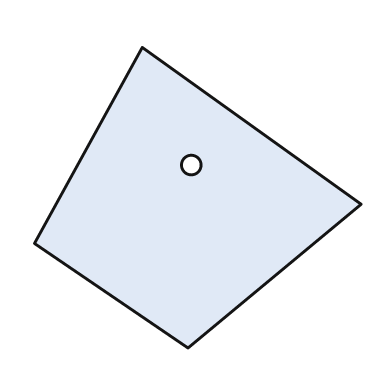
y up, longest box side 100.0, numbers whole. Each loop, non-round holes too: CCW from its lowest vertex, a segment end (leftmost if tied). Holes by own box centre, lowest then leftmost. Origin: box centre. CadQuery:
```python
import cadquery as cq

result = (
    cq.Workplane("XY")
    .moveTo(-3.0, -46.0)
    .lineTo(50.0, -2.0)
    .lineTo(-17.0, 46.0)
    .lineTo(-50.0, -14.0)
    .close()
    .moveTo(-2.0, 10.0)
    .circle(3.0)
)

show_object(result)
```